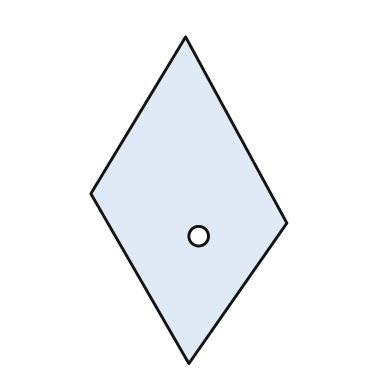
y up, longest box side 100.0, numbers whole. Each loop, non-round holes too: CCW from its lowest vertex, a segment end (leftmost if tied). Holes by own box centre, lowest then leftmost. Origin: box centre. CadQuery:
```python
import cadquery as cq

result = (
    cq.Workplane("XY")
    .moveTo(0.0, -50.0)
    .lineTo(30.0, -7.0)
    .lineTo(-1.0, 50.0)
    .lineTo(-30.0, 2.0)
    .close()
    .moveTo(3.0, -11.0)
    .circle(3.0)
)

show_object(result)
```